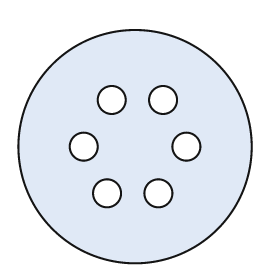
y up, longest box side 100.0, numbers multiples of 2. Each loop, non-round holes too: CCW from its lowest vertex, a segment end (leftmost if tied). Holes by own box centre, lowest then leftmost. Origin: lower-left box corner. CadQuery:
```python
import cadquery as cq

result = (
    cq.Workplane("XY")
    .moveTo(50.0, 50.0)
    .circle(50.0)
    .moveTo(38.0, 30.0)
    .circle(6.0)
    .moveTo(60.0, 30.0)
    .circle(6.0)
    .moveTo(28.0, 50.0)
    .circle(6.0)
    .moveTo(72.0, 50.0)
    .circle(6.0)
    .moveTo(40.0, 70.0)
    .circle(6.0)
    .moveTo(62.0, 70.0)
    .circle(6.0)
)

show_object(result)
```